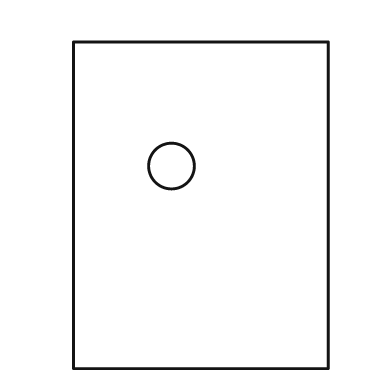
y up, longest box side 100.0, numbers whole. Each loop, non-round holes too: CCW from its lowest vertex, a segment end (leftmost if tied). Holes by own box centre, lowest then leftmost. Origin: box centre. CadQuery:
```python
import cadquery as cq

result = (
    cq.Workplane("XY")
    .moveTo(-39.0, -50.0)
    .lineTo(39.0, -50.0)
    .lineTo(39.0, 50.0)
    .lineTo(-39.0, 50.0)
    .close()
    .moveTo(-9.0, 12.0)
    .circle(7.0)
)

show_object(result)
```